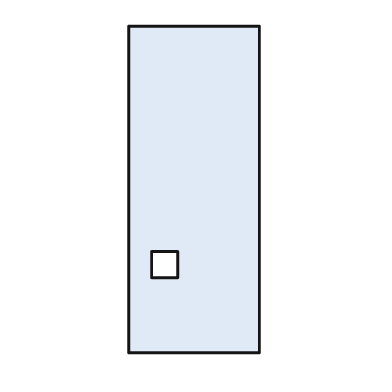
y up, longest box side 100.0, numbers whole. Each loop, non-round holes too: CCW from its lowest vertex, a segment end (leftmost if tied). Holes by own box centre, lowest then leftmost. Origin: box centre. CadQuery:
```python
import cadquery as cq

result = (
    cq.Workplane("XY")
    .moveTo(-20.0, -50.0)
    .lineTo(20.0, -50.0)
    .lineTo(20.0, 50.0)
    .lineTo(-20.0, 50.0)
    .close()
    .moveTo(-13.0, -27.0)
    .lineTo(-5.0, -27.0)
    .lineTo(-5.0, -19.0)
    .lineTo(-13.0, -19.0)
    .close()
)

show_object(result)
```